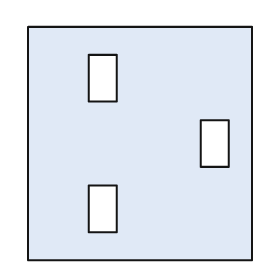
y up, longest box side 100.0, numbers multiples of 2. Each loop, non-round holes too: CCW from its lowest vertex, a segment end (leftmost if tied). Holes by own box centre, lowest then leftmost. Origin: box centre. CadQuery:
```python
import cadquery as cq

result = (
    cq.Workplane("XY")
    .moveTo(-48.0, -50.0)
    .lineTo(48.0, -50.0)
    .lineTo(48.0, 50.0)
    .lineTo(-48.0, 50.0)
    .close()
    .moveTo(-22.0, -38.0)
    .lineTo(-10.0, -38.0)
    .lineTo(-10.0, -18.0)
    .lineTo(-22.0, -18.0)
    .close()
    .moveTo(26.0, -10.0)
    .lineTo(38.0, -10.0)
    .lineTo(38.0, 10.0)
    .lineTo(26.0, 10.0)
    .close()
    .moveTo(-22.0, 18.0)
    .lineTo(-10.0, 18.0)
    .lineTo(-10.0, 38.0)
    .lineTo(-22.0, 38.0)
    .close()
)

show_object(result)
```